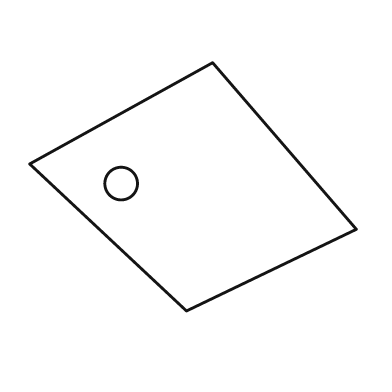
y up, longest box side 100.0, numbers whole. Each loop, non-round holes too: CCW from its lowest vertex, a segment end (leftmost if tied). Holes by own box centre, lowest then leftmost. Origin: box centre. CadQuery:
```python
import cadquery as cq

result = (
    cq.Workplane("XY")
    .moveTo(-2.0, -38.0)
    .lineTo(50.0, -13.0)
    .lineTo(6.0, 38.0)
    .lineTo(-50.0, 7.0)
    .close()
    .moveTo(-22.0, 1.0)
    .circle(5.0)
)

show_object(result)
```